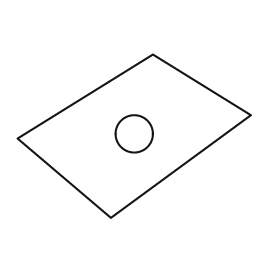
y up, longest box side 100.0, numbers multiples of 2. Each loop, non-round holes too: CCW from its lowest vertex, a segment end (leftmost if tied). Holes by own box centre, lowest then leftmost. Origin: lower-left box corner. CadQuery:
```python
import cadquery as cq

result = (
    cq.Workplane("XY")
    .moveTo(40.0, 0.0)
    .lineTo(100.0, 44.0)
    .lineTo(58.0, 70.0)
    .lineTo(0.0, 34.0)
    .close()
    .moveTo(50.0, 36.0)
    .circle(8.0)
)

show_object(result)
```